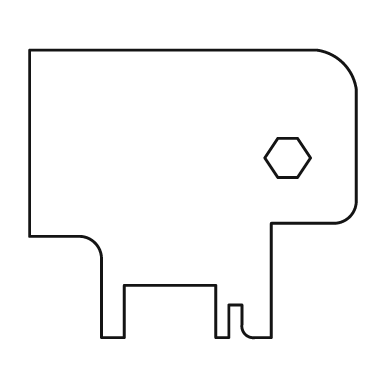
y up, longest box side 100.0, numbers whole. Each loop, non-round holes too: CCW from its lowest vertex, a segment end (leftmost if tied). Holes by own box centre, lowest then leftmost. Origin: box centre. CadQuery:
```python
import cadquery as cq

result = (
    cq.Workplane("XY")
    .moveTo(-28.0, -44.0)
    .lineTo(-21.0, -44.0)
    .lineTo(-21.0, -28.0)
    .lineTo(7.0, -28.0)
    .lineTo(7.0, -44.0)
    .lineTo(11.0, -44.0)
    .lineTo(11.0, -34.0)
    .lineTo(15.0, -34.0)
    .lineTo(15.0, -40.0)
    .threePointArc((16.0, -43.0), (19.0, -44.0))
    .lineTo(24.0, -44.0)
    .lineTo(24.0, -9.0)
    .lineTo(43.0, -9.0)
    .threePointArc((48.0, -7.0), (50.0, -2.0))
    .lineTo(50.0, 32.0)
    .threePointArc((46.0, 40.0), (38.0, 44.0))
    .lineTo(-50.0, 44.0)
    .lineTo(-50.0, -13.0)
    .lineTo(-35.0, -13.0)
    .threePointArc((-30.0, -15.0), (-28.0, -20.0))
    .close()
    .moveTo(26.0, 5.0)
    .lineTo(32.0, 5.0)
    .lineTo(36.0, 11.0)
    .lineTo(32.0, 17.0)
    .lineTo(26.0, 17.0)
    .lineTo(22.0, 11.0)
    .close()
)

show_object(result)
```